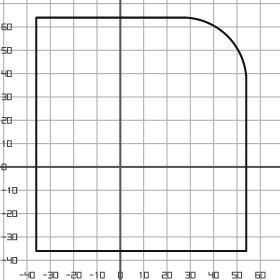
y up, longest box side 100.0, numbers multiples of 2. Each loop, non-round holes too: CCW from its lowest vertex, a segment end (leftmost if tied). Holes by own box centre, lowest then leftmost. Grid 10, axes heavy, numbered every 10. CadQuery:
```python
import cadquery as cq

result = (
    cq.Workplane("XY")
    .moveTo(-36.0, -36.0)
    .lineTo(54.0, -36.0)
    .lineTo(54.0, 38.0)
    .threePointArc((46.0, 56.0), (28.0, 64.0))
    .lineTo(-36.0, 64.0)
    .close()
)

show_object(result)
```